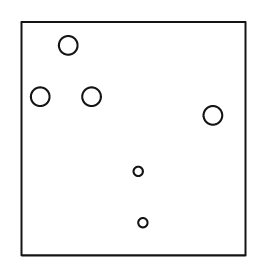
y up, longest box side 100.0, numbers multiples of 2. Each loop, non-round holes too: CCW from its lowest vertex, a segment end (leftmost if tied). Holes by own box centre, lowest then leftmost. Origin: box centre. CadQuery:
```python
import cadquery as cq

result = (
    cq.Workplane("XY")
    .moveTo(-48.0, -50.0)
    .lineTo(48.0, -50.0)
    .lineTo(48.0, 50.0)
    .lineTo(-48.0, 50.0)
    .close()
    .moveTo(4.0, -36.0)
    .circle(2.0)
    .moveTo(2.0, -14.0)
    .circle(2.0)
    .moveTo(34.0, 10.0)
    .circle(4.0)
    .moveTo(-40.0, 18.0)
    .circle(4.0)
    .moveTo(-18.0, 18.0)
    .circle(4.0)
    .moveTo(-28.0, 40.0)
    .circle(4.0)
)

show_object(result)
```